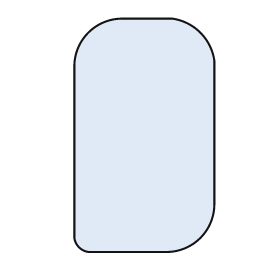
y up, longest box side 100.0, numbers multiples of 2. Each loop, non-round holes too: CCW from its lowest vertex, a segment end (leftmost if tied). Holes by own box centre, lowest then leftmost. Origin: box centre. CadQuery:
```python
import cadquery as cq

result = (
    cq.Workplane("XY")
    .moveTo(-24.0, -50.0)
    .lineTo(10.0, -50.0)
    .threePointArc((24.0, -44.0), (30.0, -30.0))
    .lineTo(30.0, 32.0)
    .threePointArc((24.0, 44.0), (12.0, 50.0))
    .lineTo(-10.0, 50.0)
    .threePointArc((-24.0, 44.0), (-30.0, 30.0))
    .lineTo(-30.0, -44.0)
    .threePointArc((-28.0, -48.0), (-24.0, -50.0))
    .close()
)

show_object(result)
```